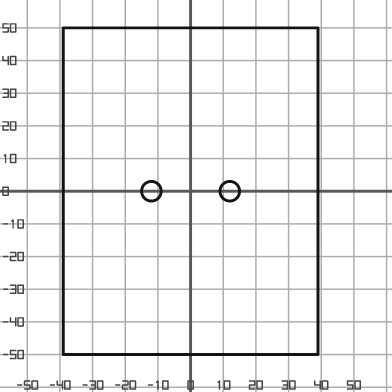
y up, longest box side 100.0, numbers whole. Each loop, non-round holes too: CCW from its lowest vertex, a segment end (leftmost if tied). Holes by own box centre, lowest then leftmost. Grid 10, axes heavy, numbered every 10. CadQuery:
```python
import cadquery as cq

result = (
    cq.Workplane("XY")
    .moveTo(-39.0, -50.0)
    .lineTo(39.0, -50.0)
    .lineTo(39.0, 50.0)
    .lineTo(-39.0, 50.0)
    .close()
    .moveTo(-12.0, 0.0)
    .circle(3.0)
    .moveTo(12.0, 0.0)
    .circle(3.0)
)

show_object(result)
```